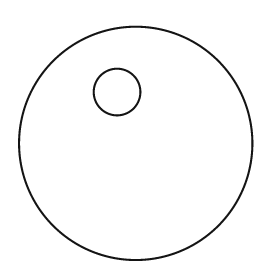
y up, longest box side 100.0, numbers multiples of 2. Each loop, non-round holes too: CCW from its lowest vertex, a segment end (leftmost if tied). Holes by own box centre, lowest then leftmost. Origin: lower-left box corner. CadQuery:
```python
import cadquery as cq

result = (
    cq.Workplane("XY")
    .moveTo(50.0, 50.0)
    .circle(50.0)
    .moveTo(42.0, 72.0)
    .circle(10.0)
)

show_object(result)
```